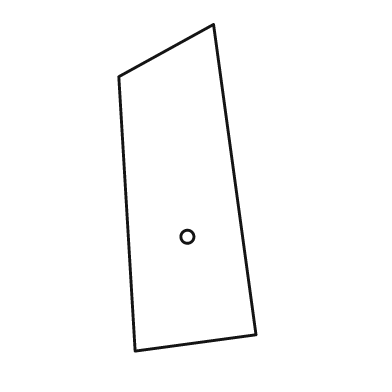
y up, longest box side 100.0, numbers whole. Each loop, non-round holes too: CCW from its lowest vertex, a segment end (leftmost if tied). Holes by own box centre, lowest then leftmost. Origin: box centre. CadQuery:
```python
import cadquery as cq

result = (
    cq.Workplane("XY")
    .moveTo(-16.0, -50.0)
    .lineTo(21.0, -45.0)
    .lineTo(8.0, 50.0)
    .lineTo(-21.0, 34.0)
    .close()
    .moveTo(0.0, -15.0)
    .circle(2.0)
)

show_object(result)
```